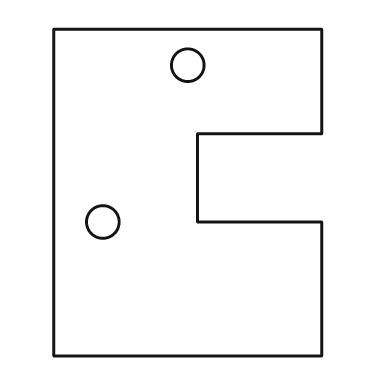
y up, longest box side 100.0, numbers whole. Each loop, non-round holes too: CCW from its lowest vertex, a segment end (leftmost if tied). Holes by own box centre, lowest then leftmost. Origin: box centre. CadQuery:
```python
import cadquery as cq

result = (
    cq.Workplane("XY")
    .moveTo(-41.0, -50.0)
    .lineTo(41.0, -50.0)
    .lineTo(41.0, -9.0)
    .lineTo(3.0, -9.0)
    .lineTo(3.0, 18.0)
    .lineTo(41.0, 18.0)
    .lineTo(41.0, 50.0)
    .lineTo(-41.0, 50.0)
    .close()
    .moveTo(-26.0, -9.0)
    .circle(5.0)
    .moveTo(0.0, 39.0)
    .circle(5.0)
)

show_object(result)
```